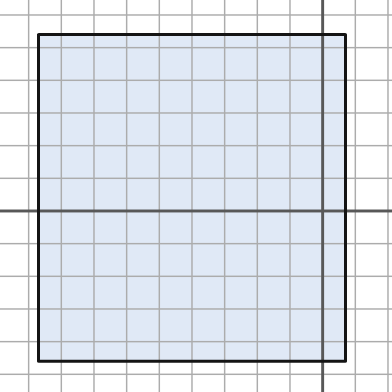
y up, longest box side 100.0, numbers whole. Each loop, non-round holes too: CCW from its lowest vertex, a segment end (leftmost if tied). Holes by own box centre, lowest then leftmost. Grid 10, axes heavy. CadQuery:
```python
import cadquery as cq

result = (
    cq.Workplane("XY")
    .moveTo(-87.0, -46.0)
    .lineTo(7.0, -46.0)
    .lineTo(7.0, 54.0)
    .lineTo(-87.0, 54.0)
    .close()
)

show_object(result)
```